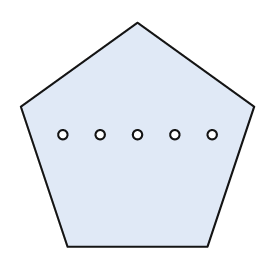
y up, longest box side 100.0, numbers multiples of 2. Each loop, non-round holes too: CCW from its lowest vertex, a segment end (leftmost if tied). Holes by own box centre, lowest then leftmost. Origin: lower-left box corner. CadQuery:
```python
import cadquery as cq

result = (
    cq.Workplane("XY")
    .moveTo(20.0, 0.0)
    .lineTo(80.0, 0.0)
    .lineTo(100.0, 60.0)
    .lineTo(50.0, 96.0)
    .lineTo(0.0, 60.0)
    .close()
    .moveTo(18.0, 48.0)
    .circle(2.0)
    .moveTo(34.0, 48.0)
    .circle(2.0)
    .moveTo(50.0, 48.0)
    .circle(2.0)
    .moveTo(66.0, 48.0)
    .circle(2.0)
    .moveTo(82.0, 48.0)
    .circle(2.0)
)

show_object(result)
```